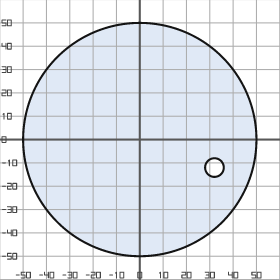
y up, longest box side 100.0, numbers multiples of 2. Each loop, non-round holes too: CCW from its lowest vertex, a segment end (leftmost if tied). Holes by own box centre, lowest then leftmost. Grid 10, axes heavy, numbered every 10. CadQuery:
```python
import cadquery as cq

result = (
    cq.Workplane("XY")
    .moveTo(0.0, 0.0)
    .circle(50.0)
    .moveTo(32.0, -12.0)
    .circle(4.0)
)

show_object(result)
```